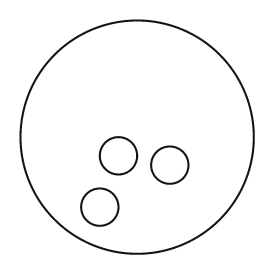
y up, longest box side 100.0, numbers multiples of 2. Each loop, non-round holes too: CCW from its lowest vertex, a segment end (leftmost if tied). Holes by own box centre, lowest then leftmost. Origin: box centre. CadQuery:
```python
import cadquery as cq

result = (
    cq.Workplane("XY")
    .moveTo(0.0, 0.0)
    .circle(50.0)
    .moveTo(-16.0, -30.0)
    .circle(8.0)
    .moveTo(14.0, -12.0)
    .circle(8.0)
    .moveTo(-8.0, -8.0)
    .circle(8.0)
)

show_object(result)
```